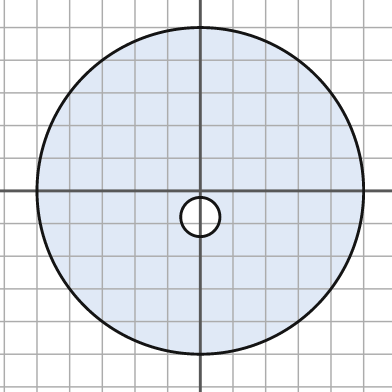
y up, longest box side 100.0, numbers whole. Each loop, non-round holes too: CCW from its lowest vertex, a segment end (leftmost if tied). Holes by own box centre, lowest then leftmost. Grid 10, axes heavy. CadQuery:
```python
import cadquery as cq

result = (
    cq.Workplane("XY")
    .moveTo(0.0, 0.0)
    .circle(50.0)
    .moveTo(0.0, -8.0)
    .circle(6.0)
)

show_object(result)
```